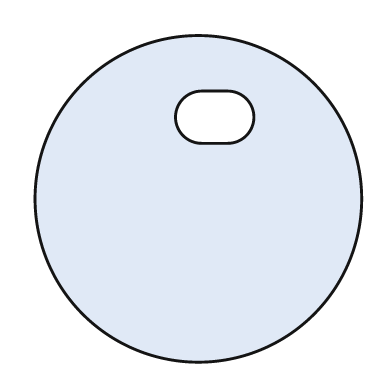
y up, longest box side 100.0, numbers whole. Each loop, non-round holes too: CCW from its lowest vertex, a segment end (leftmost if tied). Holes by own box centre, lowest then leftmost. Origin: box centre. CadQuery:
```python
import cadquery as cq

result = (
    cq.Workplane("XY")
    .moveTo(0.0, 0.0)
    .circle(50.0)
    .moveTo(1.0, 17.0)
    .lineTo(9.0, 17.0)
    .threePointArc((17.0, 25.0), (9.0, 33.0))
    .lineTo(1.0, 33.0)
    .threePointArc((-7.0, 25.0), (1.0, 17.0))
    .close()
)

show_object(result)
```